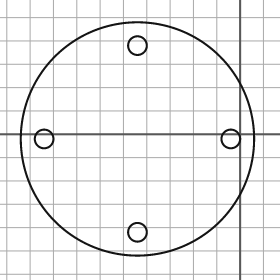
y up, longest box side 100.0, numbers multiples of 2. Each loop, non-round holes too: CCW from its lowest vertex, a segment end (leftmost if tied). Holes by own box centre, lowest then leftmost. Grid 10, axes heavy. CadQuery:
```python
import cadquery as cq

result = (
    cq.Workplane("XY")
    .moveTo(-44.0, -2.0)
    .circle(50.0)
    .moveTo(-44.0, -42.0)
    .circle(4.0)
    .moveTo(-84.0, -2.0)
    .circle(4.0)
    .moveTo(-4.0, -2.0)
    .circle(4.0)
    .moveTo(-44.0, 38.0)
    .circle(4.0)
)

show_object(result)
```